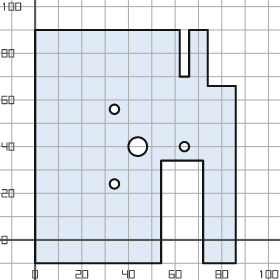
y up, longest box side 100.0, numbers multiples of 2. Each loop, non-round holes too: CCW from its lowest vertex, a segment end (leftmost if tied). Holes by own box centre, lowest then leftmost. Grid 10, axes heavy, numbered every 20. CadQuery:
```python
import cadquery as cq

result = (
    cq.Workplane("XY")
    .moveTo(0.0, -10.0)
    .lineTo(54.0, -10.0)
    .lineTo(54.0, 34.0)
    .lineTo(72.0, 34.0)
    .lineTo(72.0, -10.0)
    .lineTo(86.0, -10.0)
    .lineTo(86.0, 66.0)
    .lineTo(74.0, 66.0)
    .lineTo(74.0, 90.0)
    .lineTo(66.0, 90.0)
    .lineTo(66.0, 70.0)
    .lineTo(62.0, 70.0)
    .lineTo(62.0, 90.0)
    .lineTo(0.0, 90.0)
    .close()
    .moveTo(34.0, 24.0)
    .circle(2.0)
    .moveTo(44.0, 40.0)
    .circle(4.0)
    .moveTo(64.0, 40.0)
    .circle(2.0)
    .moveTo(34.0, 56.0)
    .circle(2.0)
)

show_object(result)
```